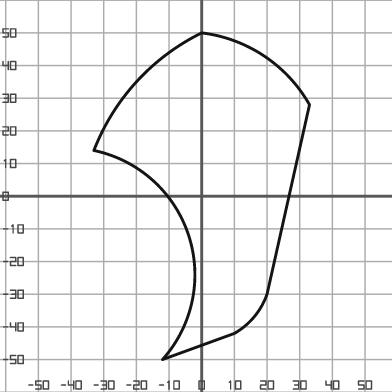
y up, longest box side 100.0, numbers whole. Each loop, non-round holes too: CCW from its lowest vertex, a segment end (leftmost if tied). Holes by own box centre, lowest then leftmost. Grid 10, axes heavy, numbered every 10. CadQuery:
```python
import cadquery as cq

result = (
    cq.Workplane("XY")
    .moveTo(-12.0, -50.0)
    .lineTo(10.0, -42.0)
    .threePointArc((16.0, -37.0), (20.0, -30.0))
    .lineTo(33.0, 28.0)
    .threePointArc((19.0, 43.0), (0.0, 50.0))
    .threePointArc((-20.0, 35.0), (-33.0, 14.0))
    .threePointArc((-4.0, -12.0), (-12.0, -50.0))
    .close()
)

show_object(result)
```